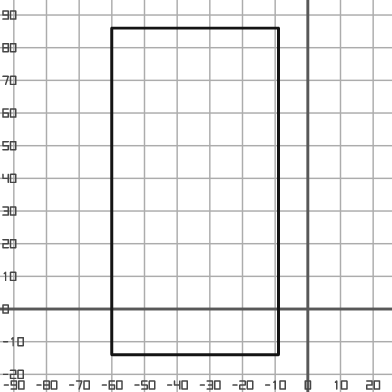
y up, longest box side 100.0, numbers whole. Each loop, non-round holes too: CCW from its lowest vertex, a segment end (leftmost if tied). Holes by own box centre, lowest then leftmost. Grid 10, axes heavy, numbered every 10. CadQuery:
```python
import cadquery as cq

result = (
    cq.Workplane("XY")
    .moveTo(-60.0, -14.0)
    .lineTo(-9.0, -14.0)
    .lineTo(-9.0, 86.0)
    .lineTo(-60.0, 86.0)
    .close()
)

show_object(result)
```